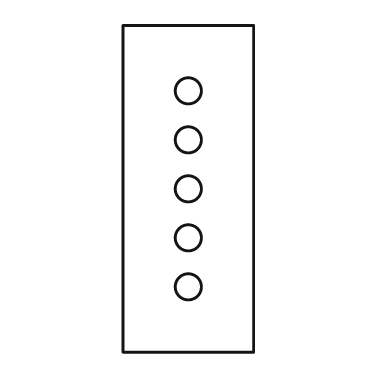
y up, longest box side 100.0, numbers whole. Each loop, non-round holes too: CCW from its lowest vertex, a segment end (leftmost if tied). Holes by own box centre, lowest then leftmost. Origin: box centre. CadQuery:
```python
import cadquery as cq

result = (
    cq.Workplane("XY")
    .moveTo(-20.0, -50.0)
    .lineTo(20.0, -50.0)
    .lineTo(20.0, 50.0)
    .lineTo(-20.0, 50.0)
    .close()
    .moveTo(0.0, -30.0)
    .circle(4.0)
    .moveTo(0.0, -15.0)
    .circle(4.0)
    .moveTo(0.0, 0.0)
    .circle(4.0)
    .moveTo(0.0, 15.0)
    .circle(4.0)
    .moveTo(0.0, 30.0)
    .circle(4.0)
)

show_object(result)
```